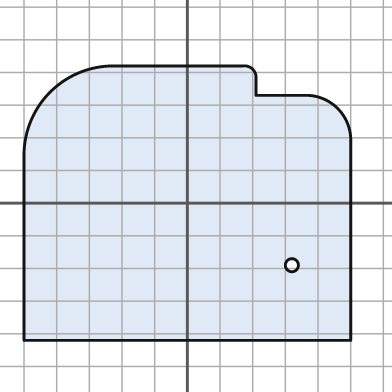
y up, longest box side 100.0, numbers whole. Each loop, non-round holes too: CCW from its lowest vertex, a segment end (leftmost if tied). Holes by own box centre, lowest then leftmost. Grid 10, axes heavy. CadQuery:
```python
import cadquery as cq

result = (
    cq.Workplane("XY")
    .moveTo(-50.0, -42.0)
    .lineTo(50.0, -42.0)
    .lineTo(50.0, 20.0)
    .threePointArc((46.0, 29.0), (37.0, 33.0))
    .lineTo(21.0, 33.0)
    .lineTo(21.0, 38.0)
    .threePointArc((20.0, 41.0), (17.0, 42.0))
    .lineTo(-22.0, 42.0)
    .threePointArc((-42.0, 34.0), (-50.0, 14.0))
    .close()
    .moveTo(32.0, -19.0)
    .circle(2.0)
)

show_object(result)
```